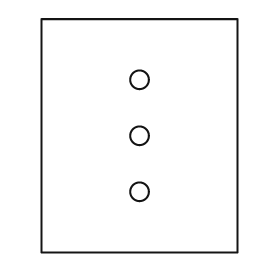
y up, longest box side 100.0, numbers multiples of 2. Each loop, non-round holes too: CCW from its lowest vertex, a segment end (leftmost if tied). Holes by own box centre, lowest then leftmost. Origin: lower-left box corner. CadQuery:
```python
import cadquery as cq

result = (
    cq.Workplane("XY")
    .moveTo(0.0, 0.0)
    .lineTo(84.0, 0.0)
    .lineTo(84.0, 100.0)
    .lineTo(0.0, 100.0)
    .close()
    .moveTo(42.0, 26.0)
    .circle(4.0)
    .moveTo(42.0, 50.0)
    .circle(4.0)
    .moveTo(42.0, 74.0)
    .circle(4.0)
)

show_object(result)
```